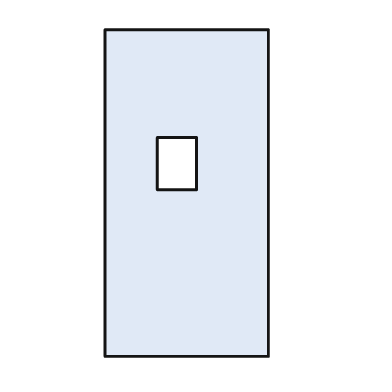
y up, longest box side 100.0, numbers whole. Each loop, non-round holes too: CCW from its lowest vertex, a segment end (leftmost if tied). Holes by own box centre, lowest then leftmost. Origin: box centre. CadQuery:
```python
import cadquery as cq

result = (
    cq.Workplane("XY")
    .moveTo(-25.0, -50.0)
    .lineTo(25.0, -50.0)
    .lineTo(25.0, 50.0)
    .lineTo(-25.0, 50.0)
    .close()
    .moveTo(-9.0, 1.0)
    .lineTo(3.0, 1.0)
    .lineTo(3.0, 17.0)
    .lineTo(-9.0, 17.0)
    .close()
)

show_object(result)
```